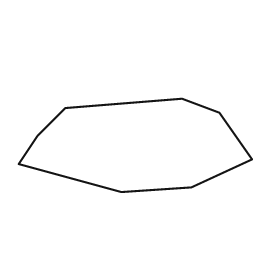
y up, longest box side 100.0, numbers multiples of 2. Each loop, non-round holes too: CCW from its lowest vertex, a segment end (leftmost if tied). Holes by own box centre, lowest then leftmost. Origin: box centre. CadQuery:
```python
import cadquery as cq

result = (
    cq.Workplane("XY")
    .moveTo(-6.0, -20.0)
    .lineTo(24.0, -18.0)
    .lineTo(50.0, -6.0)
    .lineTo(36.0, 14.0)
    .lineTo(20.0, 20.0)
    .lineTo(-30.0, 16.0)
    .lineTo(-42.0, 4.0)
    .lineTo(-50.0, -8.0)
    .close()
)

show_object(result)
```